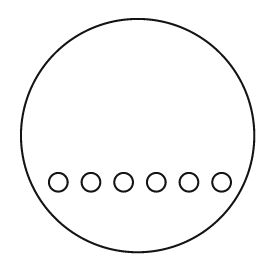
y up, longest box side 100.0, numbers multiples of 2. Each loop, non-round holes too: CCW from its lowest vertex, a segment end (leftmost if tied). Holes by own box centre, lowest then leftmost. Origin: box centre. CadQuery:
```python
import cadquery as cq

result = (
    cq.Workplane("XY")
    .moveTo(0.0, 0.0)
    .circle(50.0)
    .moveTo(-34.0, -20.0)
    .circle(4.0)
    .moveTo(-20.0, -20.0)
    .circle(4.0)
    .moveTo(-6.0, -20.0)
    .circle(4.0)
    .moveTo(8.0, -20.0)
    .circle(4.0)
    .moveTo(22.0, -20.0)
    .circle(4.0)
    .moveTo(36.0, -20.0)
    .circle(4.0)
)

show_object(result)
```